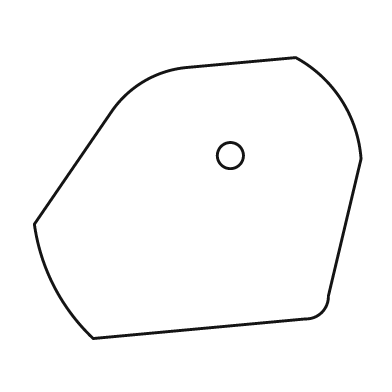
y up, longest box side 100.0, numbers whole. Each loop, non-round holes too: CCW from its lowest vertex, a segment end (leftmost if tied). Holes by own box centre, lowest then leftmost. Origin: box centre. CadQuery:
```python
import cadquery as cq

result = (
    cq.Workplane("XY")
    .moveTo(-32.0, -43.0)
    .lineTo(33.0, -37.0)
    .threePointArc((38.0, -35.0), (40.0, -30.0))
    .lineTo(50.0, 12.0)
    .threePointArc((44.0, 30.0), (30.0, 43.0))
    .lineTo(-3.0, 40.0)
    .threePointArc((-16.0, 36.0), (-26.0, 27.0))
    .lineTo(-50.0, -8.0)
    .threePointArc((-44.0, -27.0), (-32.0, -43.0))
    .close()
    .moveTo(10.0, 13.0)
    .circle(4.0)
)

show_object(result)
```